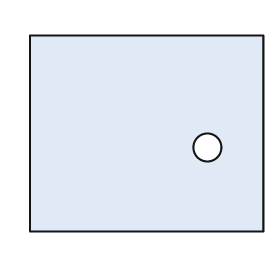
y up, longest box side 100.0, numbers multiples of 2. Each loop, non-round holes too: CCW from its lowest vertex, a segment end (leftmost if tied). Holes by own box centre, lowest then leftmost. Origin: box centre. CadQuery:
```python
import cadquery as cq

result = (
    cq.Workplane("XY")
    .moveTo(-50.0, -42.0)
    .lineTo(50.0, -42.0)
    .lineTo(50.0, 42.0)
    .lineTo(-50.0, 42.0)
    .close()
    .moveTo(26.0, -6.0)
    .circle(6.0)
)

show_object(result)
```